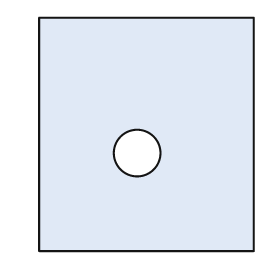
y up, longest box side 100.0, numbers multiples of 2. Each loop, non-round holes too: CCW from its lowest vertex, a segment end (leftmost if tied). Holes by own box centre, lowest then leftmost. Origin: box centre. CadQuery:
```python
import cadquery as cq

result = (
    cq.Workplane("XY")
    .moveTo(-46.0, -50.0)
    .lineTo(46.0, -50.0)
    .lineTo(46.0, 50.0)
    .lineTo(-46.0, 50.0)
    .close()
    .moveTo(-4.0, -8.0)
    .circle(10.0)
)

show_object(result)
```